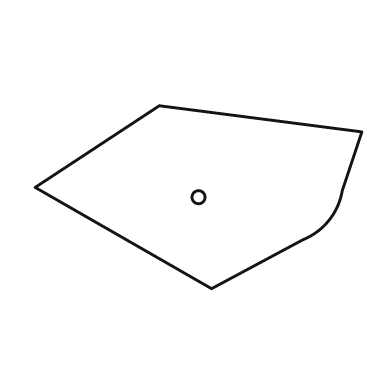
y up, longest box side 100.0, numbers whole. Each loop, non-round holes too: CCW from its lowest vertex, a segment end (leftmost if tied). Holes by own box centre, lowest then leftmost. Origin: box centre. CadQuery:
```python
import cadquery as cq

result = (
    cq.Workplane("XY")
    .moveTo(4.0, -28.0)
    .lineTo(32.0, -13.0)
    .threePointArc((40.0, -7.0), (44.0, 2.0))
    .lineTo(50.0, 20.0)
    .lineTo(-12.0, 28.0)
    .lineTo(-50.0, 3.0)
    .close()
    .moveTo(0.0, 0.0)
    .circle(2.0)
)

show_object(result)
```